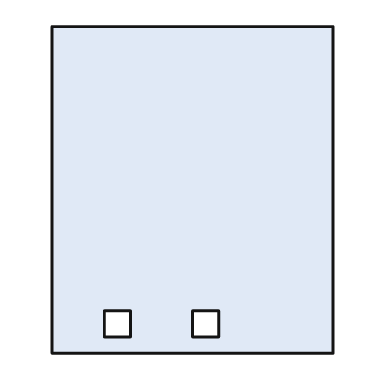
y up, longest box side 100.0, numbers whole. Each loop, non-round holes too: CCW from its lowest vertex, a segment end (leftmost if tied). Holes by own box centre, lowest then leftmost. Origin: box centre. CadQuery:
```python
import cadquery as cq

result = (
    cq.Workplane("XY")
    .moveTo(-43.0, -50.0)
    .lineTo(43.0, -50.0)
    .lineTo(43.0, 50.0)
    .lineTo(-43.0, 50.0)
    .close()
    .moveTo(-27.0, -45.0)
    .lineTo(-19.0, -45.0)
    .lineTo(-19.0, -37.0)
    .lineTo(-27.0, -37.0)
    .close()
    .moveTo(0.0, -45.0)
    .lineTo(8.0, -45.0)
    .lineTo(8.0, -37.0)
    .lineTo(0.0, -37.0)
    .close()
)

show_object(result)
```